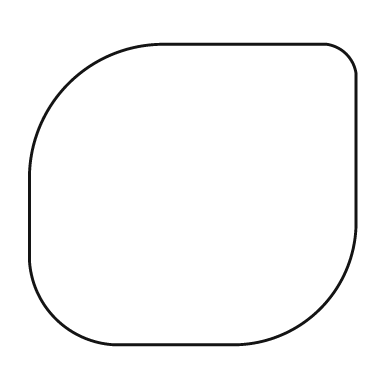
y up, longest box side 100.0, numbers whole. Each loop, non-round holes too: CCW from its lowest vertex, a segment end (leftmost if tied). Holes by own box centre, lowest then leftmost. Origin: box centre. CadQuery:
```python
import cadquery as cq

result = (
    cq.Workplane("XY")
    .moveTo(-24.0, -46.0)
    .lineTo(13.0, -46.0)
    .threePointArc((39.0, -35.0), (50.0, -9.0))
    .lineTo(50.0, 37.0)
    .threePointArc((47.0, 43.0), (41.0, 46.0))
    .lineTo(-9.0, 46.0)
    .threePointArc((-38.0, 34.0), (-50.0, 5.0))
    .lineTo(-50.0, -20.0)
    .threePointArc((-42.0, -38.0), (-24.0, -46.0))
    .close()
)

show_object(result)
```